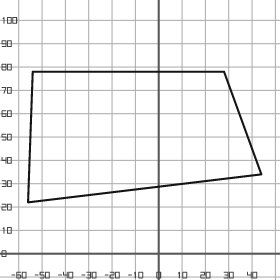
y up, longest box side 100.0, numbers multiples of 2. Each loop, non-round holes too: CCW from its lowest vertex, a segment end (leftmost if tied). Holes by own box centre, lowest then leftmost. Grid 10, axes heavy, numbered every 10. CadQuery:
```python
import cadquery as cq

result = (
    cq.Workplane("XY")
    .moveTo(-56.0, 22.0)
    .lineTo(44.0, 34.0)
    .lineTo(28.0, 78.0)
    .lineTo(-54.0, 78.0)
    .close()
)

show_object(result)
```